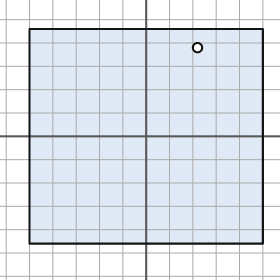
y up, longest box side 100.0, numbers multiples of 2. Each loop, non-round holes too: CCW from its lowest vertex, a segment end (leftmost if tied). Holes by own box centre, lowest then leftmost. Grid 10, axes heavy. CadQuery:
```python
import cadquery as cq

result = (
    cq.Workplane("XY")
    .moveTo(-50.0, -46.0)
    .lineTo(50.0, -46.0)
    .lineTo(50.0, 46.0)
    .lineTo(-50.0, 46.0)
    .close()
    .moveTo(22.0, 38.0)
    .circle(2.0)
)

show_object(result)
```